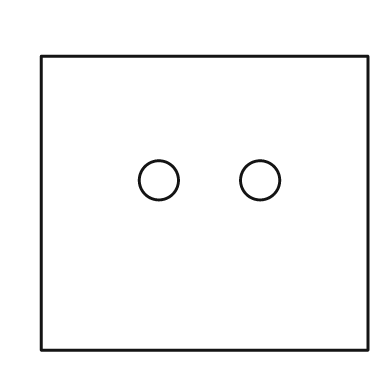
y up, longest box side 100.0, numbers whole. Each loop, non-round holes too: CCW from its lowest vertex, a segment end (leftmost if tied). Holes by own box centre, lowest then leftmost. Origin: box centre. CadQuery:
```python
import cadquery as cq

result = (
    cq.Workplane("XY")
    .moveTo(-50.0, -45.0)
    .lineTo(50.0, -45.0)
    .lineTo(50.0, 45.0)
    .lineTo(-50.0, 45.0)
    .close()
    .moveTo(-14.0, 7.0)
    .circle(6.0)
    .moveTo(17.0, 7.0)
    .circle(6.0)
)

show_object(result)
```